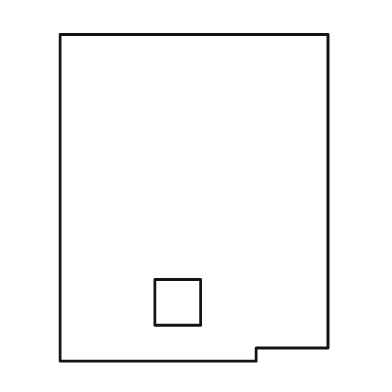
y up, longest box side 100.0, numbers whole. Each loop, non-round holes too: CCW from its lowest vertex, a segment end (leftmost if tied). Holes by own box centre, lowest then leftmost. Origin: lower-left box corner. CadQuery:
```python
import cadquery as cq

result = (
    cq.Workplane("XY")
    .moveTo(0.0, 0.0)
    .lineTo(60.0, 0.0)
    .lineTo(60.0, 4.0)
    .lineTo(82.0, 4.0)
    .lineTo(82.0, 100.0)
    .lineTo(0.0, 100.0)
    .close()
    .moveTo(29.0, 11.0)
    .lineTo(43.0, 11.0)
    .lineTo(43.0, 25.0)
    .lineTo(29.0, 25.0)
    .close()
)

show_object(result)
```